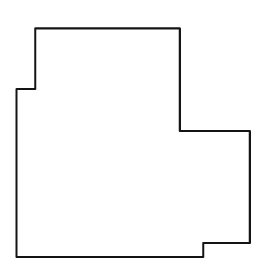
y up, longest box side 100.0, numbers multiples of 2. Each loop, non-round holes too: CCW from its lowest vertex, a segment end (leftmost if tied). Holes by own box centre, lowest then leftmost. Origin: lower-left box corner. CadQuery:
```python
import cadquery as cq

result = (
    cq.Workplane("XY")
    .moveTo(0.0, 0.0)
    .lineTo(80.0, 0.0)
    .lineTo(80.0, 6.0)
    .lineTo(100.0, 6.0)
    .lineTo(100.0, 54.0)
    .lineTo(70.0, 54.0)
    .lineTo(70.0, 98.0)
    .lineTo(8.0, 98.0)
    .lineTo(8.0, 72.0)
    .lineTo(0.0, 72.0)
    .close()
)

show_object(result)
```